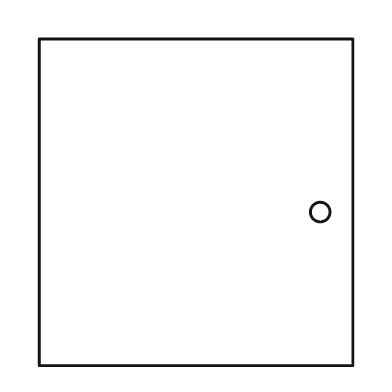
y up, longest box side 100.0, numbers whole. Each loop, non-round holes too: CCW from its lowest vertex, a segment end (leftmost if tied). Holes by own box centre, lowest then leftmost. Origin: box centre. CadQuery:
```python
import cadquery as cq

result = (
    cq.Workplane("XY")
    .moveTo(-48.0, -50.0)
    .lineTo(48.0, -50.0)
    .lineTo(48.0, 50.0)
    .lineTo(-48.0, 50.0)
    .close()
    .moveTo(38.0, -3.0)
    .circle(3.0)
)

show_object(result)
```